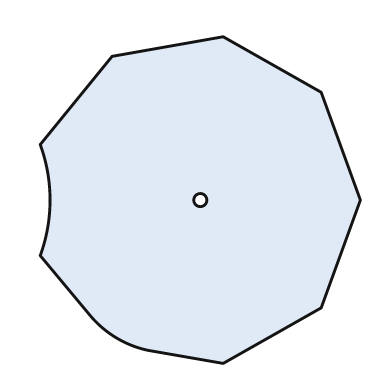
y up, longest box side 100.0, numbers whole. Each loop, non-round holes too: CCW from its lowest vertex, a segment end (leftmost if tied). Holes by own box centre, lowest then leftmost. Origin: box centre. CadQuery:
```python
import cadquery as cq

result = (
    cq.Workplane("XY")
    .moveTo(7.0, -50.0)
    .lineTo(37.0, -33.0)
    .lineTo(49.0, 0.0)
    .lineTo(37.0, 33.0)
    .lineTo(7.0, 50.0)
    .lineTo(-27.0, 44.0)
    .lineTo(-49.0, 17.0)
    .threePointArc((-46.0, 0.0), (-49.0, -17.0))
    .lineTo(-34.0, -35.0)
    .threePointArc((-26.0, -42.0), (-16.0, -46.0))
    .close()
    .moveTo(0.0, 0.0)
    .circle(2.0)
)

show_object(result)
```